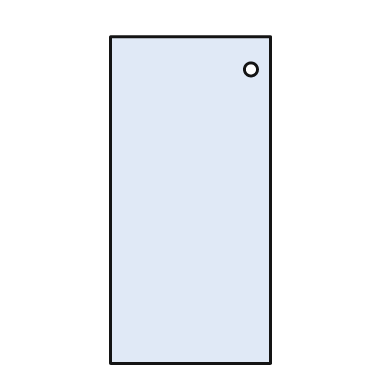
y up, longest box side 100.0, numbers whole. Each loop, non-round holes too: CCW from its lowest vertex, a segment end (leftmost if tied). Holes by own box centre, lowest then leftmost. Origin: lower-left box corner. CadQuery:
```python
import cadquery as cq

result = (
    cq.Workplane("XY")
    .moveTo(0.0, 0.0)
    .lineTo(49.0, 0.0)
    .lineTo(49.0, 100.0)
    .lineTo(0.0, 100.0)
    .close()
    .moveTo(43.0, 90.0)
    .circle(2.0)
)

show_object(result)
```